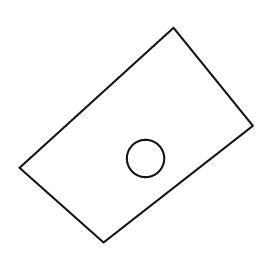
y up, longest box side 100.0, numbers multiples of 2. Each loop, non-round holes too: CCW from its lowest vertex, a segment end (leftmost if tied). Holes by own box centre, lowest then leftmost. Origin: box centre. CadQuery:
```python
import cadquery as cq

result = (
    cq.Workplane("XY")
    .moveTo(-14.0, -46.0)
    .lineTo(50.0, 4.0)
    .lineTo(16.0, 46.0)
    .lineTo(-50.0, -14.0)
    .close()
    .moveTo(4.0, -10.0)
    .circle(8.0)
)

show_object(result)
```